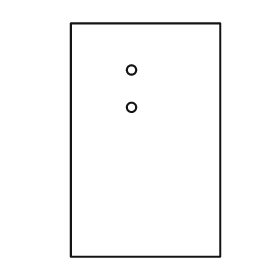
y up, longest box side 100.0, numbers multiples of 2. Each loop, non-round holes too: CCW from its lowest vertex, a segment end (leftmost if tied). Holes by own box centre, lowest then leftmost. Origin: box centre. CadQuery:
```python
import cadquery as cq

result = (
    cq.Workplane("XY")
    .moveTo(-32.0, -50.0)
    .lineTo(32.0, -50.0)
    .lineTo(32.0, 50.0)
    .lineTo(-32.0, 50.0)
    .close()
    .moveTo(-6.0, 14.0)
    .circle(2.0)
    .moveTo(-6.0, 30.0)
    .circle(2.0)
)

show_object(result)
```